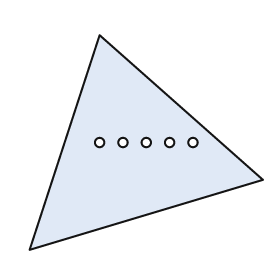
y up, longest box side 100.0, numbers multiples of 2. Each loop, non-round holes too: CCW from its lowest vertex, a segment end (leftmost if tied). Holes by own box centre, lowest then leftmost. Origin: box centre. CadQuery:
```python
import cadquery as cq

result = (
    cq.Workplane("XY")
    .moveTo(-50.0, -46.0)
    .lineTo(50.0, -16.0)
    .lineTo(-20.0, 46.0)
    .close()
    .moveTo(-20.0, 0.0)
    .circle(2.0)
    .moveTo(-10.0, 0.0)
    .circle(2.0)
    .moveTo(0.0, 0.0)
    .circle(2.0)
    .moveTo(10.0, 0.0)
    .circle(2.0)
    .moveTo(20.0, 0.0)
    .circle(2.0)
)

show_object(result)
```